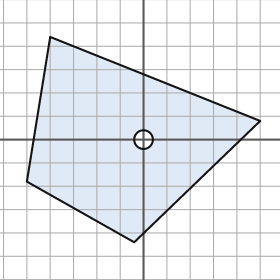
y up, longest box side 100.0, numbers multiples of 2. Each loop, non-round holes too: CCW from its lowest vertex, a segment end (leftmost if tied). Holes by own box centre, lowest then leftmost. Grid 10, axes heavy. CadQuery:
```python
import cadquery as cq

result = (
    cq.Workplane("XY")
    .moveTo(-4.0, -44.0)
    .lineTo(50.0, 8.0)
    .lineTo(-40.0, 44.0)
    .lineTo(-50.0, -18.0)
    .close()
    .moveTo(0.0, 0.0)
    .circle(4.0)
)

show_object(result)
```